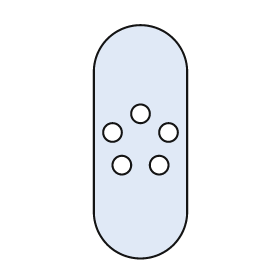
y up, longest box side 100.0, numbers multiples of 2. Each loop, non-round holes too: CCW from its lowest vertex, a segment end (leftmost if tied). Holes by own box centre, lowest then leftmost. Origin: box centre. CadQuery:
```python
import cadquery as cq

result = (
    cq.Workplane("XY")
    .moveTo(-20.0, -30.0)
    .threePointArc((0.0, -50.0), (20.0, -30.0))
    .lineTo(20.0, 30.0)
    .threePointArc((0.0, 50.0), (-20.0, 30.0))
    .close()
    .moveTo(-8.0, -10.0)
    .circle(4.0)
    .moveTo(8.0, -10.0)
    .circle(4.0)
    .moveTo(-12.0, 4.0)
    .circle(4.0)
    .moveTo(12.0, 4.0)
    .circle(4.0)
    .moveTo(0.0, 12.0)
    .circle(4.0)
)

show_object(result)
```